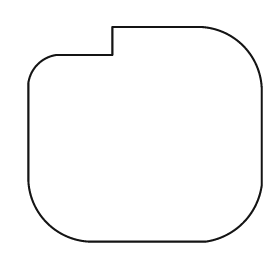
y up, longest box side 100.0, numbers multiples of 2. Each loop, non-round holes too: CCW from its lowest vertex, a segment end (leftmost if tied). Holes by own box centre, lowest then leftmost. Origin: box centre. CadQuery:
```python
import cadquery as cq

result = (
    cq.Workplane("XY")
    .moveTo(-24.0, -46.0)
    .lineTo(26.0, -46.0)
    .threePointArc((42.0, -38.0), (50.0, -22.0))
    .lineTo(50.0, 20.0)
    .threePointArc((42.0, 38.0), (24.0, 46.0))
    .lineTo(-14.0, 46.0)
    .lineTo(-14.0, 34.0)
    .lineTo(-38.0, 34.0)
    .threePointArc((-46.0, 30.0), (-50.0, 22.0))
    .lineTo(-50.0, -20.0)
    .threePointArc((-42.0, -38.0), (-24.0, -46.0))
    .close()
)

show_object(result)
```